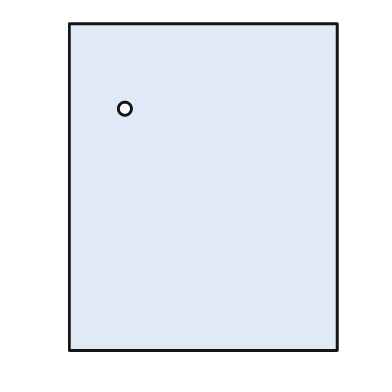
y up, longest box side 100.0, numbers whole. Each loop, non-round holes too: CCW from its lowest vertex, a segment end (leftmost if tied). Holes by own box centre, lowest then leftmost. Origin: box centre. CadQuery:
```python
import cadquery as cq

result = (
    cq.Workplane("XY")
    .moveTo(-41.0, -50.0)
    .lineTo(41.0, -50.0)
    .lineTo(41.0, 50.0)
    .lineTo(-41.0, 50.0)
    .close()
    .moveTo(-24.0, 24.0)
    .circle(2.0)
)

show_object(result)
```